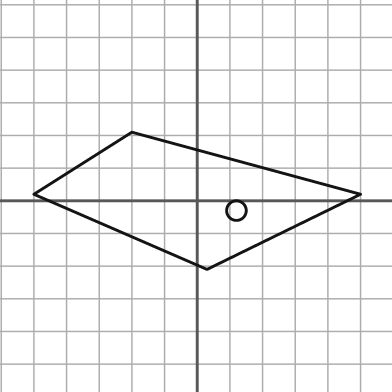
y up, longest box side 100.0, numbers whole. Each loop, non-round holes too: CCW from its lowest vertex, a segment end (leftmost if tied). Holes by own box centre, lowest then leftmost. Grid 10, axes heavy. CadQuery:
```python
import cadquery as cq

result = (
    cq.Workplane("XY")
    .moveTo(3.0, -21.0)
    .lineTo(50.0, 2.0)
    .lineTo(-20.0, 21.0)
    .lineTo(-50.0, 2.0)
    .close()
    .moveTo(12.0, -3.0)
    .circle(3.0)
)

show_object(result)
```